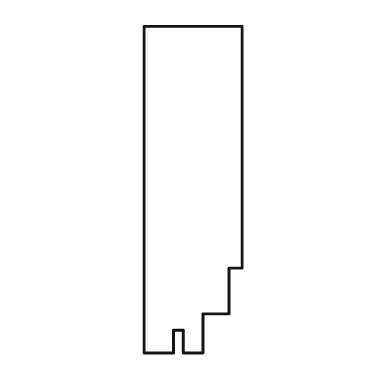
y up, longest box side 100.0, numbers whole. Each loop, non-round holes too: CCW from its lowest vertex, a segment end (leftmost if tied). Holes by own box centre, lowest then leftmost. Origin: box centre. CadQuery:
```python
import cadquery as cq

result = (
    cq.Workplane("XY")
    .moveTo(-15.0, -50.0)
    .lineTo(-6.0, -50.0)
    .lineTo(-6.0, -43.0)
    .lineTo(-3.0, -43.0)
    .lineTo(-3.0, -50.0)
    .lineTo(3.0, -50.0)
    .lineTo(3.0, -38.0)
    .lineTo(11.0, -38.0)
    .lineTo(11.0, -24.0)
    .lineTo(15.0, -24.0)
    .lineTo(15.0, 50.0)
    .lineTo(-15.0, 50.0)
    .close()
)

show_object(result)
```